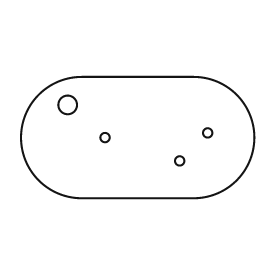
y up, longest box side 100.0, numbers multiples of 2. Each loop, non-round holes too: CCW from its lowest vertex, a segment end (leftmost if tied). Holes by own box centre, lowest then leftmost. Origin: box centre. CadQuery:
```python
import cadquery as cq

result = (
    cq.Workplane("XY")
    .moveTo(-24.0, -26.0)
    .lineTo(24.0, -26.0)
    .threePointArc((50.0, 0.0), (24.0, 26.0))
    .lineTo(-24.0, 26.0)
    .threePointArc((-50.0, 0.0), (-24.0, -26.0))
    .close()
    .moveTo(18.0, -10.0)
    .circle(2.0)
    .moveTo(-14.0, 0.0)
    .circle(2.0)
    .moveTo(30.0, 2.0)
    .circle(2.0)
    .moveTo(-30.0, 14.0)
    .circle(4.0)
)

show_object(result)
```